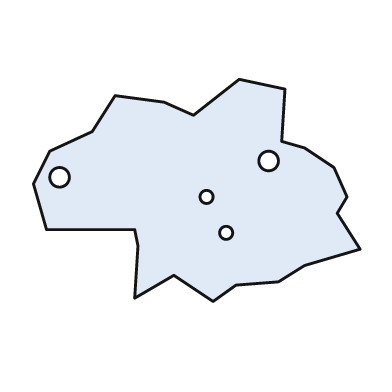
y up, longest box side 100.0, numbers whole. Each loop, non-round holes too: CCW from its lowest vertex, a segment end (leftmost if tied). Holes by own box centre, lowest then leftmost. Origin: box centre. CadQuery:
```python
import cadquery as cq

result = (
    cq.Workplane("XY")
    .moveTo(5.0, -34.0)
    .lineTo(12.0, -29.0)
    .lineTo(25.0, -28.0)
    .lineTo(33.0, -23.0)
    .lineTo(50.0, -18.0)
    .lineTo(43.0, -7.0)
    .lineTo(46.0, -2.0)
    .lineTo(42.0, 7.0)
    .lineTo(33.0, 13.0)
    .lineTo(26.0, 15.0)
    .lineTo(27.0, 31.0)
    .lineTo(13.0, 34.0)
    .lineTo(-1.0, 23.0)
    .lineTo(-10.0, 27.0)
    .lineTo(-25.0, 29.0)
    .lineTo(-32.0, 18.0)
    .lineTo(-45.0, 12.0)
    .lineTo(-50.0, 2.0)
    .lineTo(-46.0, -12.0)
    .lineTo(-19.0, -12.0)
    .lineTo(-18.0, -17.0)
    .lineTo(-19.0, -33.0)
    .lineTo(-7.0, -26.0)
    .close()
    .moveTo(9.0, -13.0)
    .circle(2.0)
    .moveTo(3.0, -2.0)
    .circle(2.0)
    .moveTo(-42.0, 4.0)
    .circle(3.0)
    .moveTo(22.0, 9.0)
    .circle(3.0)
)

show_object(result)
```